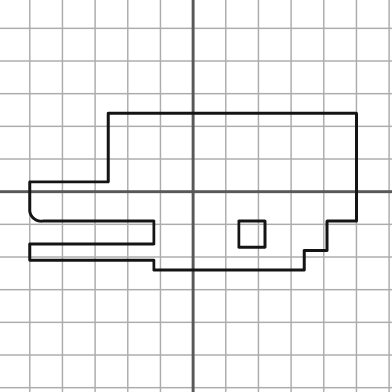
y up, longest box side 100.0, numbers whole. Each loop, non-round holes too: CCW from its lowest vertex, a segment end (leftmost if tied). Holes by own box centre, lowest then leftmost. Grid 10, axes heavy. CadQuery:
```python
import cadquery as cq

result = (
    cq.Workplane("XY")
    .moveTo(-12.0, -24.0)
    .lineTo(34.0, -24.0)
    .lineTo(34.0, -18.0)
    .lineTo(41.0, -18.0)
    .lineTo(41.0, -9.0)
    .lineTo(50.0, -9.0)
    .lineTo(50.0, 24.0)
    .lineTo(-26.0, 24.0)
    .lineTo(-26.0, 3.0)
    .lineTo(-50.0, 3.0)
    .lineTo(-50.0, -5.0)
    .threePointArc((-49.0, -8.0), (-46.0, -9.0))
    .lineTo(-12.0, -9.0)
    .lineTo(-12.0, -16.0)
    .lineTo(-50.0, -16.0)
    .lineTo(-50.0, -21.0)
    .lineTo(-12.0, -21.0)
    .close()
    .moveTo(14.0, -17.0)
    .lineTo(22.0, -17.0)
    .lineTo(22.0, -9.0)
    .lineTo(14.0, -9.0)
    .close()
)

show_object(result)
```